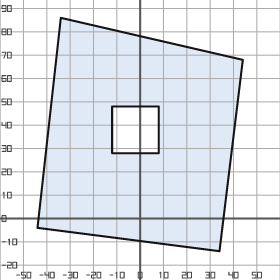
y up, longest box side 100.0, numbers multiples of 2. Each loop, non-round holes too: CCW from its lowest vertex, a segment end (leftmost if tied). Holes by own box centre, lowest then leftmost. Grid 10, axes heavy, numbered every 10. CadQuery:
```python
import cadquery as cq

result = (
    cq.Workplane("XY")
    .moveTo(34.0, -14.0)
    .lineTo(44.0, 68.0)
    .lineTo(-34.0, 86.0)
    .lineTo(-44.0, -4.0)
    .close()
    .moveTo(-12.0, 28.0)
    .lineTo(8.0, 28.0)
    .lineTo(8.0, 48.0)
    .lineTo(-12.0, 48.0)
    .close()
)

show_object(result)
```